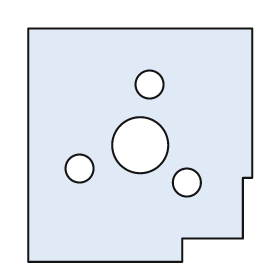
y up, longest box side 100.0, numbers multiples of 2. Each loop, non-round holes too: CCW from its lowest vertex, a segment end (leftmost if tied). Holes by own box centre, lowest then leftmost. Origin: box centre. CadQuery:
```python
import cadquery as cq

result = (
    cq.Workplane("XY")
    .moveTo(-48.0, -50.0)
    .lineTo(18.0, -50.0)
    .lineTo(18.0, -40.0)
    .lineTo(44.0, -40.0)
    .lineTo(44.0, -14.0)
    .lineTo(48.0, -14.0)
    .lineTo(48.0, 50.0)
    .lineTo(-48.0, 50.0)
    .close()
    .moveTo(20.0, -16.0)
    .circle(6.0)
    .moveTo(-26.0, -10.0)
    .circle(6.0)
    .moveTo(0.0, 0.0)
    .circle(12.0)
    .moveTo(4.0, 26.0)
    .circle(6.0)
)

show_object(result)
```